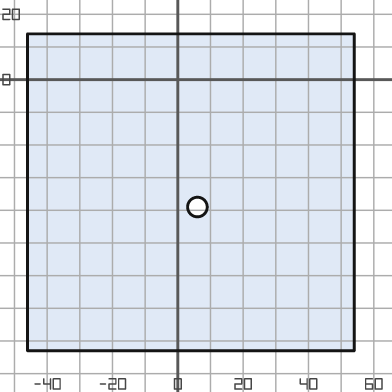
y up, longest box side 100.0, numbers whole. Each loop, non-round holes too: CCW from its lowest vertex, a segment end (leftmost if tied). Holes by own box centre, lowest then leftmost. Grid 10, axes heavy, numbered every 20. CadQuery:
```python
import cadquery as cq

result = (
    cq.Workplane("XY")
    .moveTo(-46.0, -83.0)
    .lineTo(54.0, -83.0)
    .lineTo(54.0, 14.0)
    .lineTo(-46.0, 14.0)
    .close()
    .moveTo(6.0, -39.0)
    .circle(3.0)
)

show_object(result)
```